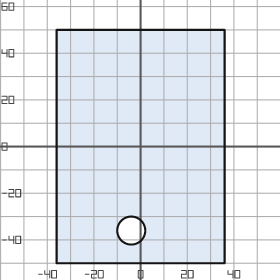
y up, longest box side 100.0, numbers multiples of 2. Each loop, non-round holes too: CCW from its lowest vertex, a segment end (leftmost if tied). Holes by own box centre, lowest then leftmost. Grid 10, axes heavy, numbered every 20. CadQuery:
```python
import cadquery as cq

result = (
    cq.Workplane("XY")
    .moveTo(-36.0, -50.0)
    .lineTo(36.0, -50.0)
    .lineTo(36.0, 50.0)
    .lineTo(-36.0, 50.0)
    .close()
    .moveTo(-4.0, -36.0)
    .circle(6.0)
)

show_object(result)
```